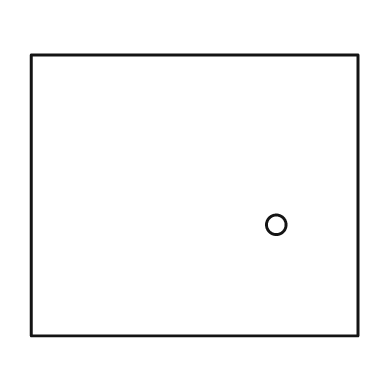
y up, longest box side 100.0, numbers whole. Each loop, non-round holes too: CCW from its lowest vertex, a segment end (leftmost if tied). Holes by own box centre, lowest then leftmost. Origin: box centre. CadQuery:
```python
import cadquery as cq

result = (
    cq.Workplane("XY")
    .moveTo(-50.0, -43.0)
    .lineTo(50.0, -43.0)
    .lineTo(50.0, 43.0)
    .lineTo(-50.0, 43.0)
    .close()
    .moveTo(25.0, -9.0)
    .circle(3.0)
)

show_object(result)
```